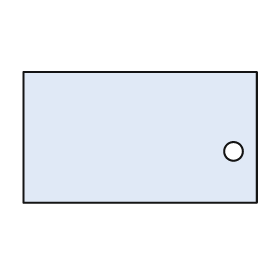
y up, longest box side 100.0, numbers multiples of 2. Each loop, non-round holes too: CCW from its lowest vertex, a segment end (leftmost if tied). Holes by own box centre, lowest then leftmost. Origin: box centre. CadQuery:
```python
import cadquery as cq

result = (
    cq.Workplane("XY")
    .moveTo(-50.0, -28.0)
    .lineTo(50.0, -28.0)
    .lineTo(50.0, 28.0)
    .lineTo(-50.0, 28.0)
    .close()
    .moveTo(40.0, -6.0)
    .circle(4.0)
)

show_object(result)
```